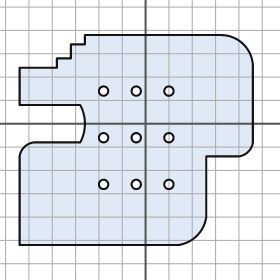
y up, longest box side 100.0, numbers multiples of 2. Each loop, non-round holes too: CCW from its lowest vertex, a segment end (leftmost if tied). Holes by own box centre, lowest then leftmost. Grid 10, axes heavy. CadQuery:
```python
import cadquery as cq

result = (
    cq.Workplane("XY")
    .moveTo(-54.0, -52.0)
    .lineTo(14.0, -52.0)
    .threePointArc((22.0, -48.0), (26.0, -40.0))
    .lineTo(26.0, -14.0)
    .lineTo(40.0, -14.0)
    .threePointArc((44.0, -12.0), (46.0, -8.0))
    .lineTo(46.0, 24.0)
    .threePointArc((42.0, 34.0), (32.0, 38.0))
    .lineTo(-26.0, 38.0)
    .lineTo(-26.0, 34.0)
    .lineTo(-32.0, 34.0)
    .lineTo(-32.0, 28.0)
    .lineTo(-38.0, 28.0)
    .lineTo(-38.0, 24.0)
    .lineTo(-54.0, 24.0)
    .lineTo(-54.0, 8.0)
    .lineTo(-28.0, 8.0)
    .threePointArc((-26.0, 0.0), (-28.0, -8.0))
    .lineTo(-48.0, -8.0)
    .threePointArc((-52.0, -10.0), (-54.0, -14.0))
    .close()
    .moveTo(-18.0, -26.0)
    .circle(2.0)
    .moveTo(-4.0, -26.0)
    .circle(2.0)
    .moveTo(10.0, -26.0)
    .circle(2.0)
    .moveTo(-18.0, -6.0)
    .circle(2.0)
    .moveTo(-4.0, -6.0)
    .circle(2.0)
    .moveTo(10.0, -6.0)
    .circle(2.0)
    .moveTo(-18.0, 14.0)
    .circle(2.0)
    .moveTo(-4.0, 14.0)
    .circle(2.0)
    .moveTo(10.0, 14.0)
    .circle(2.0)
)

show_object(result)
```